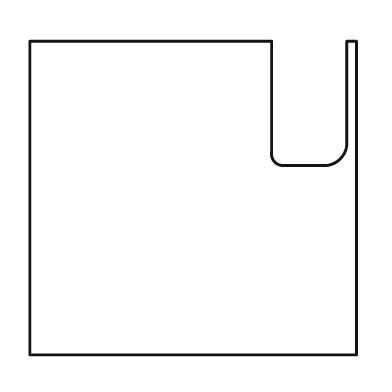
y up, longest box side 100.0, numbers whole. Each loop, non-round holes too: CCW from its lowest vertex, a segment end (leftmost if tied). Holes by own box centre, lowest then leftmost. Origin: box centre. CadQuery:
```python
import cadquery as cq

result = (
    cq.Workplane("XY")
    .moveTo(-50.0, -48.0)
    .lineTo(50.0, -48.0)
    .lineTo(50.0, 48.0)
    .lineTo(47.0, 48.0)
    .lineTo(47.0, 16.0)
    .threePointArc((45.0, 12.0), (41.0, 10.0))
    .lineTo(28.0, 10.0)
    .threePointArc((25.0, 11.0), (24.0, 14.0))
    .lineTo(24.0, 48.0)
    .lineTo(-50.0, 48.0)
    .close()
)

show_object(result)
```